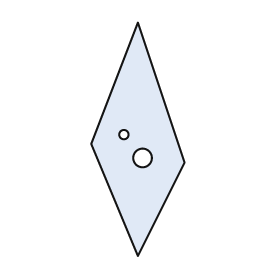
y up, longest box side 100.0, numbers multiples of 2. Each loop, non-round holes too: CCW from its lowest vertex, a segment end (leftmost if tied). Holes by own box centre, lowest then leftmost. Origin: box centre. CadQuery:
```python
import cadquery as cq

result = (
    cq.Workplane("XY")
    .moveTo(0.0, -50.0)
    .lineTo(20.0, -10.0)
    .lineTo(0.0, 50.0)
    .lineTo(-20.0, -2.0)
    .close()
    .moveTo(2.0, -8.0)
    .circle(4.0)
    .moveTo(-6.0, 2.0)
    .circle(2.0)
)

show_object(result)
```